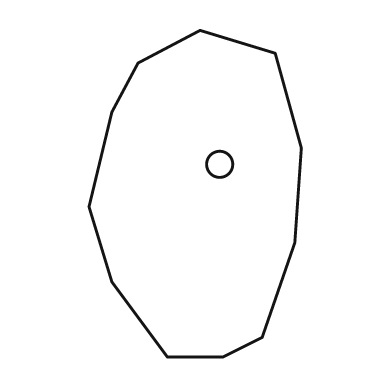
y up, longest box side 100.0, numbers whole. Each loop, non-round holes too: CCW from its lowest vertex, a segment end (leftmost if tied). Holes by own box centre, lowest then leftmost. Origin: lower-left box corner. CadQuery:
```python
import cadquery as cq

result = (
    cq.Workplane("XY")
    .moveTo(24.0, 0.0)
    .lineTo(41.0, 0.0)
    .lineTo(53.0, 6.0)
    .lineTo(63.0, 35.0)
    .lineTo(65.0, 64.0)
    .lineTo(57.0, 93.0)
    .lineTo(34.0, 100.0)
    .lineTo(15.0, 90.0)
    .lineTo(7.0, 75.0)
    .lineTo(0.0, 46.0)
    .lineTo(7.0, 23.0)
    .close()
    .moveTo(40.0, 59.0)
    .circle(4.0)
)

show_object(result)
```